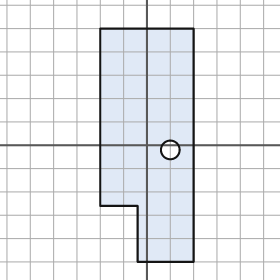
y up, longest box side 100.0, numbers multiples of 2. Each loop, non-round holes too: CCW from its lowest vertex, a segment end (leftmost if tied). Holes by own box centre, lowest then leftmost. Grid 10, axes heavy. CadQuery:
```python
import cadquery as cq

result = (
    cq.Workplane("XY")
    .moveTo(-4.0, -50.0)
    .lineTo(20.0, -50.0)
    .lineTo(20.0, 50.0)
    .lineTo(-20.0, 50.0)
    .lineTo(-20.0, -26.0)
    .lineTo(-4.0, -26.0)
    .close()
    .moveTo(10.0, -2.0)
    .circle(4.0)
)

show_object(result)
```